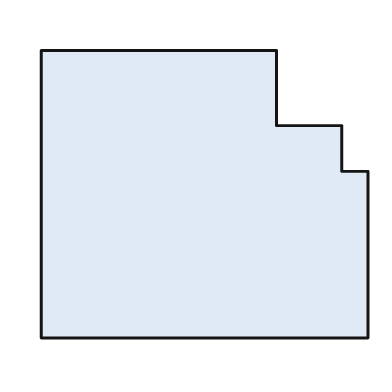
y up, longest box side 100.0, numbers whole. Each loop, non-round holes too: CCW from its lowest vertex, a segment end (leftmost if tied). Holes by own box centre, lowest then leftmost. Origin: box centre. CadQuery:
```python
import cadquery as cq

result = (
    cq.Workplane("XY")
    .moveTo(-50.0, -44.0)
    .lineTo(50.0, -44.0)
    .lineTo(50.0, 7.0)
    .lineTo(42.0, 7.0)
    .lineTo(42.0, 21.0)
    .lineTo(22.0, 21.0)
    .lineTo(22.0, 44.0)
    .lineTo(-50.0, 44.0)
    .close()
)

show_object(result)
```